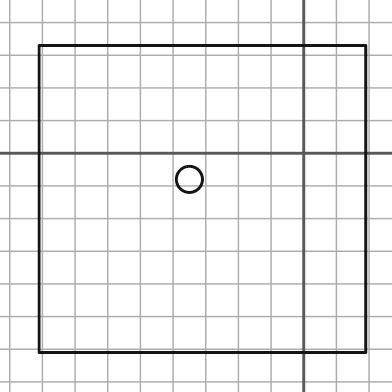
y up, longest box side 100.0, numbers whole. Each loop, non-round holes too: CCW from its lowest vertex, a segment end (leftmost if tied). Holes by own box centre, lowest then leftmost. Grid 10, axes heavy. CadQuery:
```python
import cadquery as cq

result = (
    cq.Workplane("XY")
    .moveTo(-81.0, -61.0)
    .lineTo(19.0, -61.0)
    .lineTo(19.0, 33.0)
    .lineTo(-81.0, 33.0)
    .close()
    .moveTo(-35.0, -8.0)
    .circle(4.0)
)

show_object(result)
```